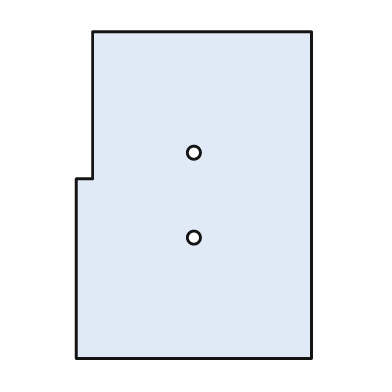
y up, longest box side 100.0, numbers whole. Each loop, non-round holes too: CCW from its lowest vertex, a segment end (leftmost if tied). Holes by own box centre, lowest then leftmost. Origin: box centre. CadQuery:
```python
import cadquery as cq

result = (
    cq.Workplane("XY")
    .moveTo(-36.0, -50.0)
    .lineTo(36.0, -50.0)
    .lineTo(36.0, 50.0)
    .lineTo(-31.0, 50.0)
    .lineTo(-31.0, 5.0)
    .lineTo(-36.0, 5.0)
    .close()
    .moveTo(0.0, -13.0)
    .circle(2.0)
    .moveTo(0.0, 13.0)
    .circle(2.0)
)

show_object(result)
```